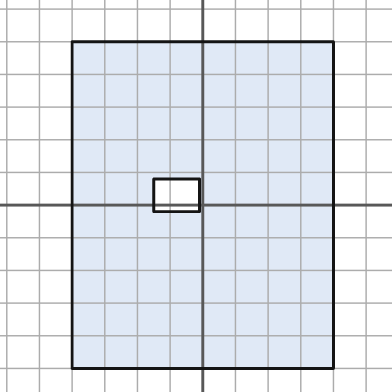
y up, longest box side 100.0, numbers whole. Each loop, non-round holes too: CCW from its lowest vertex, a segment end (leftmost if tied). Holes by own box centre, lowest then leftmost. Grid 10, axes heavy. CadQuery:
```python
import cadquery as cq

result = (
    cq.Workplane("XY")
    .moveTo(-40.0, -50.0)
    .lineTo(40.0, -50.0)
    .lineTo(40.0, 50.0)
    .lineTo(-40.0, 50.0)
    .close()
    .moveTo(-15.0, -2.0)
    .lineTo(-1.0, -2.0)
    .lineTo(-1.0, 8.0)
    .lineTo(-15.0, 8.0)
    .close()
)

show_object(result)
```